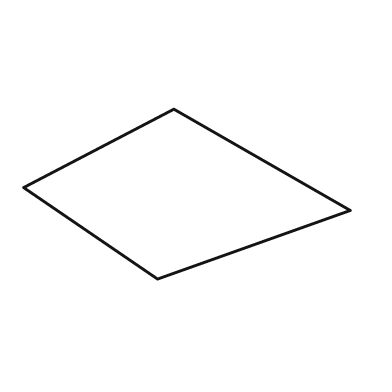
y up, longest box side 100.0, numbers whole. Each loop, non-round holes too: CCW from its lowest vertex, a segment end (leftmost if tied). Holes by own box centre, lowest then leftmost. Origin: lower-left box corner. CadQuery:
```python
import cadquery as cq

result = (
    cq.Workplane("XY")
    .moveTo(41.0, 0.0)
    .lineTo(100.0, 21.0)
    .lineTo(46.0, 52.0)
    .lineTo(0.0, 28.0)
    .close()
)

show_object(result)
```